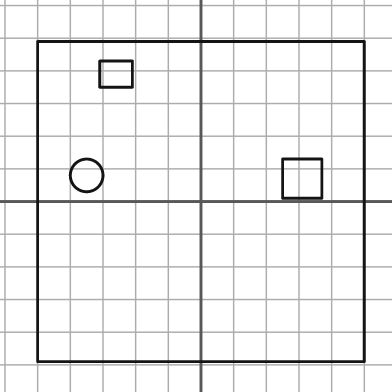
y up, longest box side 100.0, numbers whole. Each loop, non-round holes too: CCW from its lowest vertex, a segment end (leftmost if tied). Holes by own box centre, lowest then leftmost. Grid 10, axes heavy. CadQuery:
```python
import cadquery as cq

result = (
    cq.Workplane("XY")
    .moveTo(-50.0, -49.0)
    .lineTo(50.0, -49.0)
    .lineTo(50.0, 49.0)
    .lineTo(-50.0, 49.0)
    .close()
    .moveTo(25.0, 1.0)
    .lineTo(37.0, 1.0)
    .lineTo(37.0, 13.0)
    .lineTo(25.0, 13.0)
    .close()
    .moveTo(-35.0, 8.0)
    .circle(5.0)
    .moveTo(-31.0, 35.0)
    .lineTo(-21.0, 35.0)
    .lineTo(-21.0, 43.0)
    .lineTo(-31.0, 43.0)
    .close()
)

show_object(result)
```